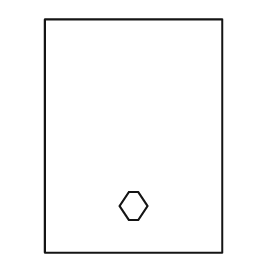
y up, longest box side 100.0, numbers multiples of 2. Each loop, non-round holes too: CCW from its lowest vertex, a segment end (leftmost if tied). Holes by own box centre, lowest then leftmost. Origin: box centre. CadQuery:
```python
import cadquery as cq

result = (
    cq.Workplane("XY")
    .moveTo(-38.0, -50.0)
    .lineTo(38.0, -50.0)
    .lineTo(38.0, 50.0)
    .lineTo(-38.0, 50.0)
    .close()
    .moveTo(-2.0, -36.0)
    .lineTo(2.0, -36.0)
    .lineTo(6.0, -30.0)
    .lineTo(2.0, -24.0)
    .lineTo(-2.0, -24.0)
    .lineTo(-6.0, -30.0)
    .close()
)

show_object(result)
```